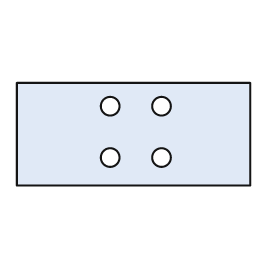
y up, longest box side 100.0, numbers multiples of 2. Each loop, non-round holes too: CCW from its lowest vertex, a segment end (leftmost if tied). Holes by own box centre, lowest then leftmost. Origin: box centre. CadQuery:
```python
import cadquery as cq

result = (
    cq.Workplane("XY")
    .moveTo(-50.0, -22.0)
    .lineTo(50.0, -22.0)
    .lineTo(50.0, 22.0)
    .lineTo(-50.0, 22.0)
    .close()
    .moveTo(-10.0, -10.0)
    .circle(4.0)
    .moveTo(12.0, -10.0)
    .circle(4.0)
    .moveTo(-10.0, 12.0)
    .circle(4.0)
    .moveTo(12.0, 12.0)
    .circle(4.0)
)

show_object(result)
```